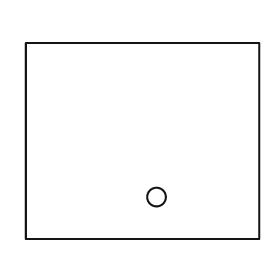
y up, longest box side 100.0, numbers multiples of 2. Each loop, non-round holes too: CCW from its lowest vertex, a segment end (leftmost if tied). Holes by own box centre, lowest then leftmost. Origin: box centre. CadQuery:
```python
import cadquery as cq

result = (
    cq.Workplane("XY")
    .moveTo(-50.0, -42.0)
    .lineTo(50.0, -42.0)
    .lineTo(50.0, 42.0)
    .lineTo(-50.0, 42.0)
    .close()
    .moveTo(6.0, -24.0)
    .circle(4.0)
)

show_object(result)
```